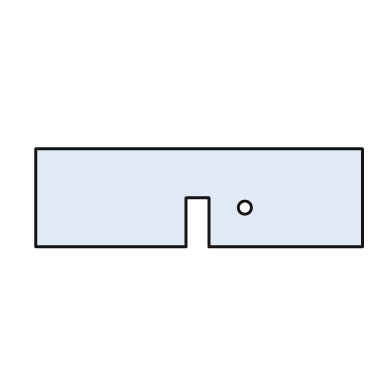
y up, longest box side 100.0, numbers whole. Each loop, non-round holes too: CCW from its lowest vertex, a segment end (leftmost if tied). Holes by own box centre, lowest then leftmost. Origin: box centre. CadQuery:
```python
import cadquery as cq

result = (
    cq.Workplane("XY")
    .moveTo(-50.0, -15.0)
    .lineTo(-4.0, -15.0)
    .lineTo(-4.0, 0.0)
    .lineTo(3.0, 0.0)
    .lineTo(3.0, -15.0)
    .lineTo(50.0, -15.0)
    .lineTo(50.0, 15.0)
    .lineTo(-50.0, 15.0)
    .close()
    .moveTo(14.0, -3.0)
    .circle(2.0)
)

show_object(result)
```